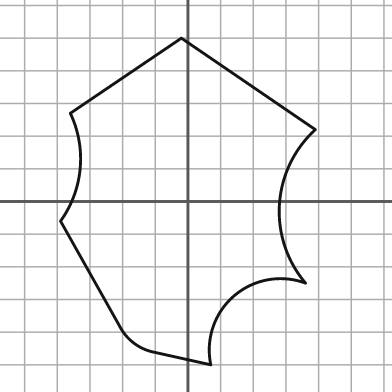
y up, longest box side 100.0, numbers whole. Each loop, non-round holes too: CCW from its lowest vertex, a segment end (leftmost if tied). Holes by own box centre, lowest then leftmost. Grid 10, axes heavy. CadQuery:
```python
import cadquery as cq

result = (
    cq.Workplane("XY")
    .moveTo(7.0, -50.0)
    .threePointArc((14.0, -29.0), (36.0, -25.0))
    .threePointArc((28.0, -1.0), (39.0, 22.0))
    .lineTo(-2.0, 50.0)
    .lineTo(-36.0, 27.0)
    .threePointArc((-33.0, 10.0), (-39.0, -6.0))
    .lineTo(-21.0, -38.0)
    .threePointArc((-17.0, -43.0), (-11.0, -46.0))
    .close()
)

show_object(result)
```